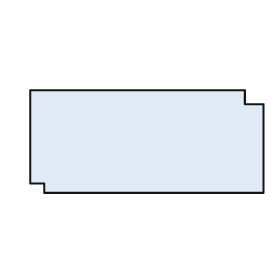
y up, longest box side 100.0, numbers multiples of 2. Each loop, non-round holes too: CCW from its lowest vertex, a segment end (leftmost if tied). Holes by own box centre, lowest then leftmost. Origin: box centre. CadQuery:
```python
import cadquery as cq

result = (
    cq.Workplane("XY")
    .moveTo(-44.0, -22.0)
    .lineTo(50.0, -22.0)
    .lineTo(50.0, 16.0)
    .lineTo(42.0, 16.0)
    .lineTo(42.0, 22.0)
    .lineTo(-50.0, 22.0)
    .lineTo(-50.0, -18.0)
    .lineTo(-44.0, -18.0)
    .close()
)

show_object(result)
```